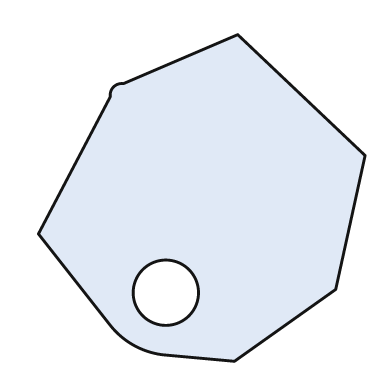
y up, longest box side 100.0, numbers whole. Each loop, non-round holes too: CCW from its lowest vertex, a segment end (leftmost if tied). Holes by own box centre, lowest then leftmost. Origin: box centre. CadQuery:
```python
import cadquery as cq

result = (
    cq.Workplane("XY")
    .moveTo(10.0, -50.0)
    .lineTo(41.0, -28.0)
    .lineTo(50.0, 13.0)
    .lineTo(11.0, 50.0)
    .lineTo(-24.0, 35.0)
    .threePointArc((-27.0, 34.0), (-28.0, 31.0))
    .lineTo(-50.0, -11.0)
    .lineTo(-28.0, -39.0)
    .threePointArc((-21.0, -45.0), (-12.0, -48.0))
    .close()
    .moveTo(-11.0, -29.0)
    .circle(10.0)
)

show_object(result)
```